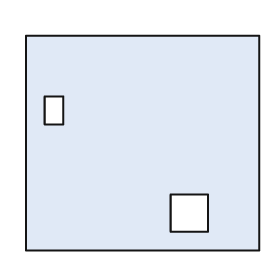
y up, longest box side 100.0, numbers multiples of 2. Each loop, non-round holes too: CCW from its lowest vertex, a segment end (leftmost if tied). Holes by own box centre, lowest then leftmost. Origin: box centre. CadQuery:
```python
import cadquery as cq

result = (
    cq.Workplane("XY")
    .moveTo(-50.0, -46.0)
    .lineTo(50.0, -46.0)
    .lineTo(50.0, 46.0)
    .lineTo(-50.0, 46.0)
    .close()
    .moveTo(12.0, -38.0)
    .lineTo(28.0, -38.0)
    .lineTo(28.0, -22.0)
    .lineTo(12.0, -22.0)
    .close()
    .moveTo(-42.0, 8.0)
    .lineTo(-34.0, 8.0)
    .lineTo(-34.0, 20.0)
    .lineTo(-42.0, 20.0)
    .close()
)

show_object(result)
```